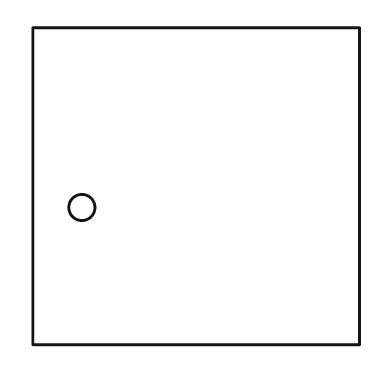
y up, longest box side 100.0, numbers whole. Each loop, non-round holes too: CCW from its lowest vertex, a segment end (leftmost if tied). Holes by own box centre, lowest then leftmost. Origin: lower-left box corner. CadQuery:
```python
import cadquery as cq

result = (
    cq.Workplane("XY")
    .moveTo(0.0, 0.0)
    .lineTo(100.0, 0.0)
    .lineTo(100.0, 97.0)
    .lineTo(0.0, 97.0)
    .close()
    .moveTo(15.0, 42.0)
    .circle(4.0)
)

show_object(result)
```